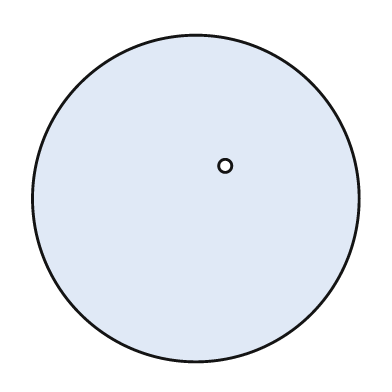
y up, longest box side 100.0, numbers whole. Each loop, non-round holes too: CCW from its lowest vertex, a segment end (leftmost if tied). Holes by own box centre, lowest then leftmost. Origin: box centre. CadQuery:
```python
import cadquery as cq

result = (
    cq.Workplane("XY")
    .moveTo(0.0, 0.0)
    .circle(50.0)
    .moveTo(9.0, 10.0)
    .circle(2.0)
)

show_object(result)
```